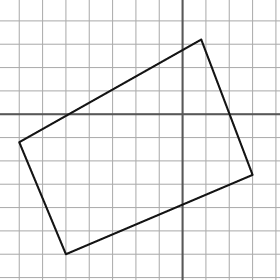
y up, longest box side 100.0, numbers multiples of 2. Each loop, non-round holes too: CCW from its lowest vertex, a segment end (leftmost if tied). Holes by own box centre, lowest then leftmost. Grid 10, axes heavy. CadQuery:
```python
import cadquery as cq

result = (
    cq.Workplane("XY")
    .moveTo(-50.0, -60.0)
    .lineTo(30.0, -26.0)
    .lineTo(8.0, 32.0)
    .lineTo(-70.0, -12.0)
    .close()
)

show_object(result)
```